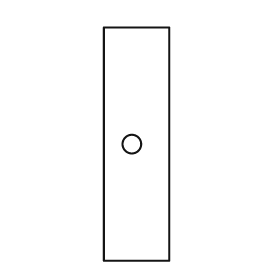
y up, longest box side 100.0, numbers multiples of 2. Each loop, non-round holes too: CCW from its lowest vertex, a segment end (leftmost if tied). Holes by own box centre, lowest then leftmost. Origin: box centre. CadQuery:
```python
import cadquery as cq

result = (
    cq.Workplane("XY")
    .moveTo(-14.0, -50.0)
    .lineTo(14.0, -50.0)
    .lineTo(14.0, 50.0)
    .lineTo(-14.0, 50.0)
    .close()
    .moveTo(-2.0, 0.0)
    .circle(4.0)
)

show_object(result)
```